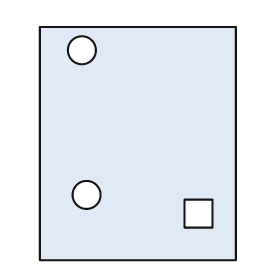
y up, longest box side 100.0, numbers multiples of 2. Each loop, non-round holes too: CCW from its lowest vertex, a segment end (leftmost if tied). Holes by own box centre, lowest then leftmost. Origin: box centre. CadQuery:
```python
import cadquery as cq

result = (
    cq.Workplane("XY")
    .moveTo(-42.0, -50.0)
    .lineTo(42.0, -50.0)
    .lineTo(42.0, 50.0)
    .lineTo(-42.0, 50.0)
    .close()
    .moveTo(20.0, -36.0)
    .lineTo(32.0, -36.0)
    .lineTo(32.0, -24.0)
    .lineTo(20.0, -24.0)
    .close()
    .moveTo(-22.0, -22.0)
    .circle(6.0)
    .moveTo(-24.0, 40.0)
    .circle(6.0)
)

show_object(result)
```